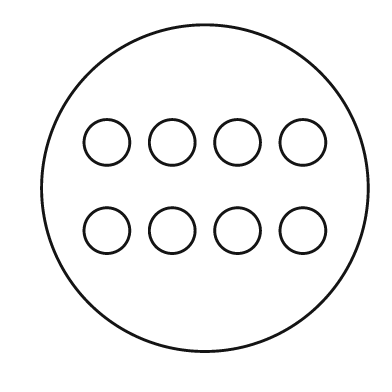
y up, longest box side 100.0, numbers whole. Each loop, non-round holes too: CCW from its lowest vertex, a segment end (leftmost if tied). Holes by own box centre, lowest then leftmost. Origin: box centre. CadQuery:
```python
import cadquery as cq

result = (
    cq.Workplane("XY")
    .moveTo(0.0, 0.0)
    .circle(50.0)
    .moveTo(-30.0, -13.0)
    .circle(7.0)
    .moveTo(-10.0, -13.0)
    .circle(7.0)
    .moveTo(10.0, -13.0)
    .circle(7.0)
    .moveTo(30.0, -13.0)
    .circle(7.0)
    .moveTo(-30.0, 14.0)
    .circle(7.0)
    .moveTo(-10.0, 14.0)
    .circle(7.0)
    .moveTo(10.0, 14.0)
    .circle(7.0)
    .moveTo(30.0, 14.0)
    .circle(7.0)
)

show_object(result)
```